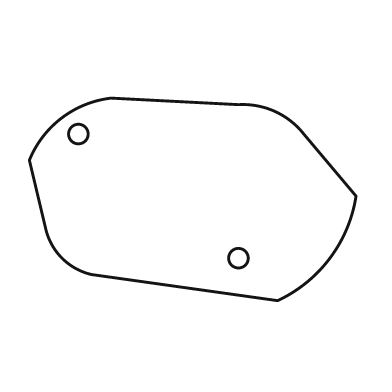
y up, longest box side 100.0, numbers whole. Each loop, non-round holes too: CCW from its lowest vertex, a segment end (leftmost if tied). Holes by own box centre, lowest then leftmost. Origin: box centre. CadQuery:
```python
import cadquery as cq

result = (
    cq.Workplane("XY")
    .moveTo(26.0, -31.0)
    .threePointArc((42.0, -18.0), (50.0, 1.0))
    .lineTo(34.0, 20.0)
    .threePointArc((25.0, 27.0), (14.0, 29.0))
    .lineTo(-25.0, 31.0)
    .threePointArc((-40.0, 25.0), (-50.0, 12.0))
    .lineTo(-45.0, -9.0)
    .threePointArc((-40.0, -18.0), (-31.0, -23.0))
    .close()
    .moveTo(14.0, -18.0)
    .circle(3.0)
    .moveTo(-35.0, 20.0)
    .circle(3.0)
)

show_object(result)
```